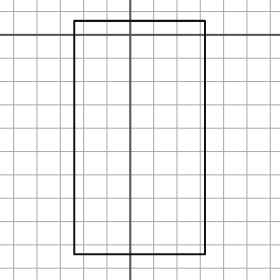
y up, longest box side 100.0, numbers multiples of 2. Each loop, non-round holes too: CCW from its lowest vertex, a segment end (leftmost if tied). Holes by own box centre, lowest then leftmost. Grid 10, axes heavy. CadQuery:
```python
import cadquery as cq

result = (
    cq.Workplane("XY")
    .moveTo(-24.0, -94.0)
    .lineTo(32.0, -94.0)
    .lineTo(32.0, 6.0)
    .lineTo(-24.0, 6.0)
    .close()
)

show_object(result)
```